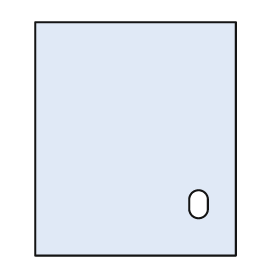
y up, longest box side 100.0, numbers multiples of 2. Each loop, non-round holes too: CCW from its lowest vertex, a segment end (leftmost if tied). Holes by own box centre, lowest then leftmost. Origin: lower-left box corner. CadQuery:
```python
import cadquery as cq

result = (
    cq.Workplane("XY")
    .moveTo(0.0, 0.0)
    .lineTo(86.0, 0.0)
    .lineTo(86.0, 100.0)
    .lineTo(0.0, 100.0)
    .close()
    .moveTo(66.0, 20.0)
    .threePointArc((70.0, 16.0), (74.0, 20.0))
    .lineTo(74.0, 24.0)
    .threePointArc((70.0, 28.0), (66.0, 24.0))
    .close()
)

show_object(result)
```